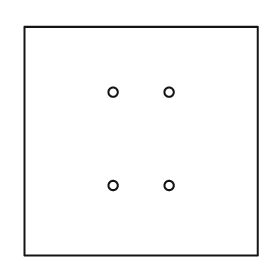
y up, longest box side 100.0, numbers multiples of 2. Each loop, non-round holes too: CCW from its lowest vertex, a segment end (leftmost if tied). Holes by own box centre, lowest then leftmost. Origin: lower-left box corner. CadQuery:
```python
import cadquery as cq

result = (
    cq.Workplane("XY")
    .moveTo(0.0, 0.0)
    .lineTo(100.0, 0.0)
    .lineTo(100.0, 98.0)
    .lineTo(0.0, 98.0)
    .close()
    .moveTo(38.0, 30.0)
    .circle(2.0)
    .moveTo(62.0, 30.0)
    .circle(2.0)
    .moveTo(38.0, 70.0)
    .circle(2.0)
    .moveTo(62.0, 70.0)
    .circle(2.0)
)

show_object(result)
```